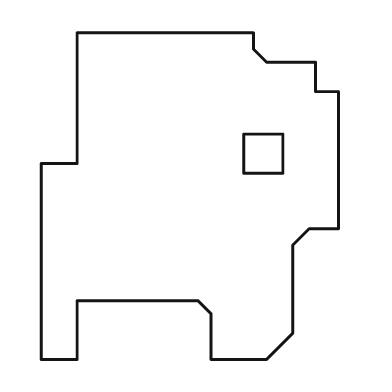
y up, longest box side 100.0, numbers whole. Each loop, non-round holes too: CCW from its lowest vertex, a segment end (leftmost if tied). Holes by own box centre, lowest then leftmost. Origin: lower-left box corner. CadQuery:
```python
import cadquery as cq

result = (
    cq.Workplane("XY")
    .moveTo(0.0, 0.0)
    .lineTo(11.0, 0.0)
    .lineTo(11.0, 18.0)
    .lineTo(48.0, 18.0)
    .lineTo(52.0, 14.0)
    .lineTo(52.0, 0.0)
    .lineTo(69.0, 0.0)
    .lineTo(77.0, 8.0)
    .lineTo(77.0, 35.0)
    .lineTo(82.0, 40.0)
    .lineTo(91.0, 40.0)
    .lineTo(91.0, 82.0)
    .lineTo(84.0, 82.0)
    .lineTo(84.0, 91.0)
    .lineTo(69.0, 91.0)
    .lineTo(65.0, 95.0)
    .lineTo(65.0, 100.0)
    .lineTo(11.0, 100.0)
    .lineTo(11.0, 60.0)
    .lineTo(0.0, 60.0)
    .close()
    .moveTo(62.0, 57.0)
    .lineTo(74.0, 57.0)
    .lineTo(74.0, 69.0)
    .lineTo(62.0, 69.0)
    .close()
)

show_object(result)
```